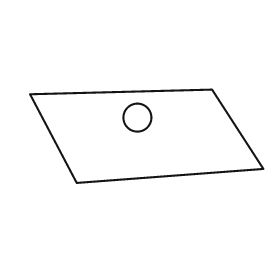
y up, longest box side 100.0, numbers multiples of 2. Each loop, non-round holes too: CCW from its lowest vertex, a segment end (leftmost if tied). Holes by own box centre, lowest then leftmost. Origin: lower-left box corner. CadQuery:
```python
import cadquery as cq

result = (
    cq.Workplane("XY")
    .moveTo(20.0, 0.0)
    .lineTo(100.0, 6.0)
    .lineTo(78.0, 40.0)
    .lineTo(0.0, 38.0)
    .close()
    .moveTo(46.0, 28.0)
    .circle(6.0)
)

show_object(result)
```